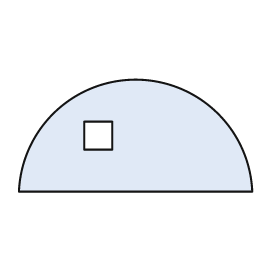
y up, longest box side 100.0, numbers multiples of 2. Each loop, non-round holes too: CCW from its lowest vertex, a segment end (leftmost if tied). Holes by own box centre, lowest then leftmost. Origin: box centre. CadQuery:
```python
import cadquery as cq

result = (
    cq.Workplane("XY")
    .moveTo(-50.0, -24.0)
    .lineTo(50.0, -24.0)
    .threePointArc((0.0, 24.0), (-50.0, -24.0))
    .close()
    .moveTo(-22.0, -6.0)
    .lineTo(-10.0, -6.0)
    .lineTo(-10.0, 6.0)
    .lineTo(-22.0, 6.0)
    .close()
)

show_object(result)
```